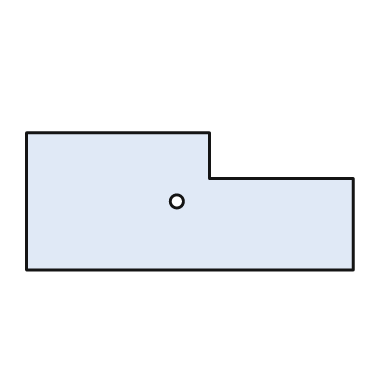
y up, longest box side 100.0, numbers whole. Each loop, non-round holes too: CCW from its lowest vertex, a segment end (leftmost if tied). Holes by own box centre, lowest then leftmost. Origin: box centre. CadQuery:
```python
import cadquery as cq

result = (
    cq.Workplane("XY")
    .moveTo(-50.0, -21.0)
    .lineTo(50.0, -21.0)
    .lineTo(50.0, 7.0)
    .lineTo(6.0, 7.0)
    .lineTo(6.0, 21.0)
    .lineTo(-50.0, 21.0)
    .close()
    .moveTo(-4.0, 0.0)
    .circle(2.0)
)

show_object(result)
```